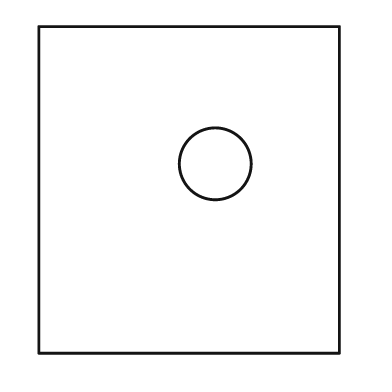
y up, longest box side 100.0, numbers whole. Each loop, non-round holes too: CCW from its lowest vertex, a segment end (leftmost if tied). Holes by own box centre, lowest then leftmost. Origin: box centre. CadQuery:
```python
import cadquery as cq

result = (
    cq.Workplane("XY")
    .moveTo(-46.0, -50.0)
    .lineTo(46.0, -50.0)
    .lineTo(46.0, 50.0)
    .lineTo(-46.0, 50.0)
    .close()
    .moveTo(8.0, 8.0)
    .circle(11.0)
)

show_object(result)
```